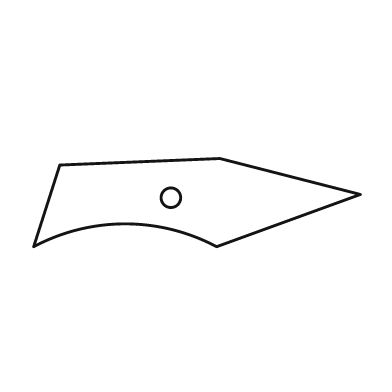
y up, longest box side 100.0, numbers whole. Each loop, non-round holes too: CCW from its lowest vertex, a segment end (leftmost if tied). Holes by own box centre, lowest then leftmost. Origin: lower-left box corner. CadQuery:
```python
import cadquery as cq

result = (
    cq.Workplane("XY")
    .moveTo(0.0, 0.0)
    .threePointArc((28.0, 7.0), (56.0, 0.0))
    .lineTo(100.0, 16.0)
    .lineTo(57.0, 27.0)
    .lineTo(8.0, 25.0)
    .close()
    .moveTo(42.0, 15.0)
    .circle(3.0)
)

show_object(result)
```